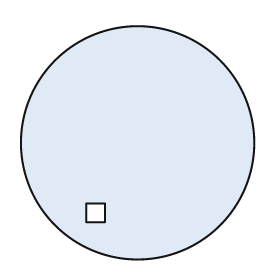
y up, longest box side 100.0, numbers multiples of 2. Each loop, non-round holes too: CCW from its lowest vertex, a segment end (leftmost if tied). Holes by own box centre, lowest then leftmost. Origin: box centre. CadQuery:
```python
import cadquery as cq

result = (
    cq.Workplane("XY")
    .moveTo(0.0, 0.0)
    .circle(50.0)
    .moveTo(-22.0, -34.0)
    .lineTo(-14.0, -34.0)
    .lineTo(-14.0, -26.0)
    .lineTo(-22.0, -26.0)
    .close()
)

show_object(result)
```